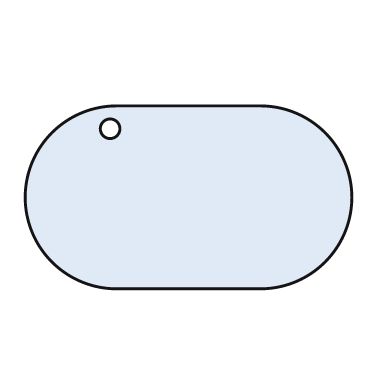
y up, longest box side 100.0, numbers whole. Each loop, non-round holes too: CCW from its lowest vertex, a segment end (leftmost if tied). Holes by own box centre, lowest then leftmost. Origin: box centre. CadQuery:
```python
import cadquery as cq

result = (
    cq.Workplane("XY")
    .moveTo(-22.0, -28.0)
    .lineTo(22.0, -28.0)
    .threePointArc((50.0, 0.0), (22.0, 28.0))
    .lineTo(-22.0, 28.0)
    .threePointArc((-50.0, 0.0), (-22.0, -28.0))
    .close()
    .moveTo(-24.0, 21.0)
    .circle(3.0)
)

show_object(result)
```